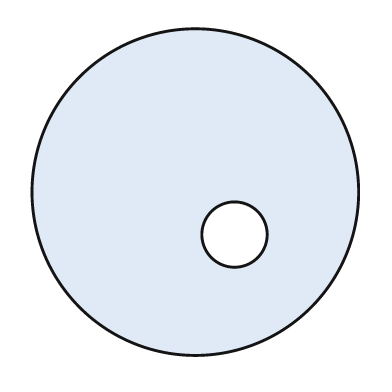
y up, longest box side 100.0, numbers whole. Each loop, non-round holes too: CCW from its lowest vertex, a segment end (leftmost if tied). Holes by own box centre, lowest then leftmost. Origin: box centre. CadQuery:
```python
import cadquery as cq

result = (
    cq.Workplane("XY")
    .moveTo(0.0, 0.0)
    .circle(50.0)
    .moveTo(12.0, -13.0)
    .circle(10.0)
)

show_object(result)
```